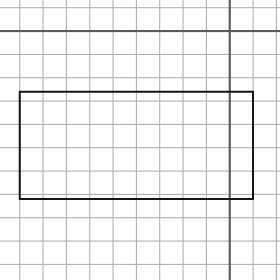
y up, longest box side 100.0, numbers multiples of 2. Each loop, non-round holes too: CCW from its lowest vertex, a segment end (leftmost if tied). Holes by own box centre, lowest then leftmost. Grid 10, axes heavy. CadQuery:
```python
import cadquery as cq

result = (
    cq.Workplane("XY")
    .moveTo(-90.0, -72.0)
    .lineTo(10.0, -72.0)
    .lineTo(10.0, -26.0)
    .lineTo(-90.0, -26.0)
    .close()
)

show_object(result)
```